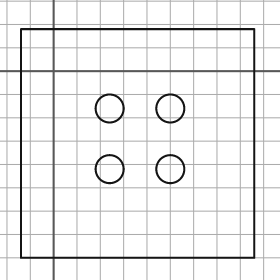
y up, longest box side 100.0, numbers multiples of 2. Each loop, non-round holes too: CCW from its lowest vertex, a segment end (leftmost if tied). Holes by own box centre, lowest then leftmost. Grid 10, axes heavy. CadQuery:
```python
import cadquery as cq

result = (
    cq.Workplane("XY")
    .moveTo(-14.0, -80.0)
    .lineTo(86.0, -80.0)
    .lineTo(86.0, 18.0)
    .lineTo(-14.0, 18.0)
    .close()
    .moveTo(24.0, -42.0)
    .circle(6.0)
    .moveTo(50.0, -42.0)
    .circle(6.0)
    .moveTo(24.0, -16.0)
    .circle(6.0)
    .moveTo(50.0, -16.0)
    .circle(6.0)
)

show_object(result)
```